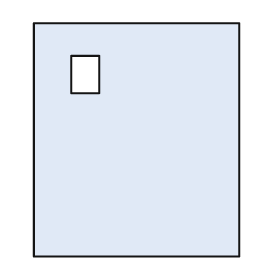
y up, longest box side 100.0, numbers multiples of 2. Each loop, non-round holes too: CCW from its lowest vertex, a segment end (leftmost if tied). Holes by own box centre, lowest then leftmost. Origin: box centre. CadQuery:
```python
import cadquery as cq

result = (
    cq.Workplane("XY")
    .moveTo(-44.0, -50.0)
    .lineTo(44.0, -50.0)
    .lineTo(44.0, 50.0)
    .lineTo(-44.0, 50.0)
    .close()
    .moveTo(-28.0, 20.0)
    .lineTo(-16.0, 20.0)
    .lineTo(-16.0, 36.0)
    .lineTo(-28.0, 36.0)
    .close()
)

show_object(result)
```